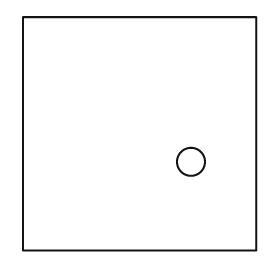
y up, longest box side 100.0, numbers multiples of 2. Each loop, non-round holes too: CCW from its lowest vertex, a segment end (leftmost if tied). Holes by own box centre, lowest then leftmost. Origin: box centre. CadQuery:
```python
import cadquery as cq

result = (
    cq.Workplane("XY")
    .moveTo(-50.0, -50.0)
    .lineTo(50.0, -50.0)
    .lineTo(50.0, 50.0)
    .lineTo(-50.0, 50.0)
    .close()
    .moveTo(22.0, -12.0)
    .circle(6.0)
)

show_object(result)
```